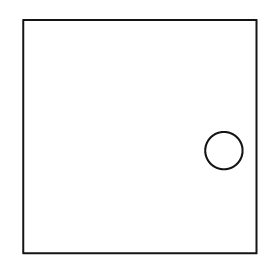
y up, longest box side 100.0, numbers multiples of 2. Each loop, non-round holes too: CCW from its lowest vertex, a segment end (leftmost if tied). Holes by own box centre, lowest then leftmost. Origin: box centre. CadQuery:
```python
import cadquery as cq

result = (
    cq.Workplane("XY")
    .moveTo(-50.0, -50.0)
    .lineTo(50.0, -50.0)
    .lineTo(50.0, 50.0)
    .lineTo(-50.0, 50.0)
    .close()
    .moveTo(36.0, -6.0)
    .circle(8.0)
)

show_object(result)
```